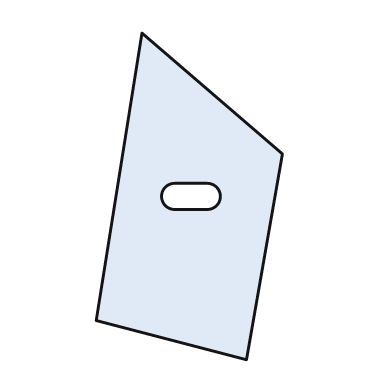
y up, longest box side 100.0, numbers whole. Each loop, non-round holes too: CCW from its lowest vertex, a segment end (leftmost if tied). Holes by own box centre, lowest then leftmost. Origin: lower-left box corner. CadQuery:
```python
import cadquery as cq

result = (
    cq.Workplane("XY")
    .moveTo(46.0, 0.0)
    .lineTo(57.0, 63.0)
    .lineTo(14.0, 100.0)
    .lineTo(0.0, 12.0)
    .close()
    .moveTo(24.0, 46.0)
    .lineTo(34.0, 46.0)
    .threePointArc((38.0, 50.0), (34.0, 54.0))
    .lineTo(24.0, 54.0)
    .threePointArc((20.0, 50.0), (24.0, 46.0))
    .close()
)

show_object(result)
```